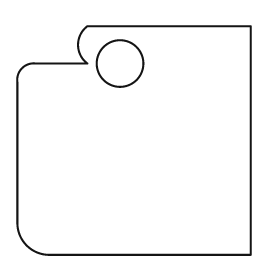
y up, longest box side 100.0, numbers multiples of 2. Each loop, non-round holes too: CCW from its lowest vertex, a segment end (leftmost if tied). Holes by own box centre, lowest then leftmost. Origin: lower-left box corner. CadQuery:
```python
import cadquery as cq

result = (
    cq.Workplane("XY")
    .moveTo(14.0, 0.0)
    .lineTo(100.0, 0.0)
    .lineTo(100.0, 98.0)
    .lineTo(30.0, 98.0)
    .threePointArc((26.0, 90.0), (30.0, 82.0))
    .lineTo(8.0, 82.0)
    .threePointArc((2.0, 80.0), (0.0, 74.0))
    .lineTo(0.0, 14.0)
    .threePointArc((4.0, 4.0), (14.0, 0.0))
    .close()
    .moveTo(44.0, 82.0)
    .circle(10.0)
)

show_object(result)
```